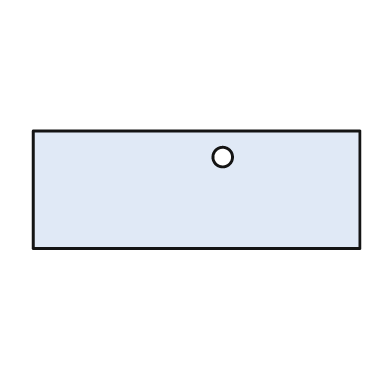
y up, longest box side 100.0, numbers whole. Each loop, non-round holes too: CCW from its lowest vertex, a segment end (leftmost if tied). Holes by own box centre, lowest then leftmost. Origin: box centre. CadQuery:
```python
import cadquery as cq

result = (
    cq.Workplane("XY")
    .moveTo(-50.0, -18.0)
    .lineTo(50.0, -18.0)
    .lineTo(50.0, 18.0)
    .lineTo(-50.0, 18.0)
    .close()
    .moveTo(8.0, 10.0)
    .circle(3.0)
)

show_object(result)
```